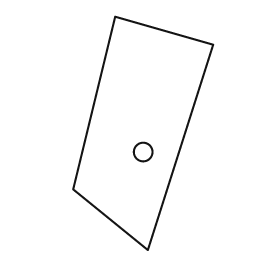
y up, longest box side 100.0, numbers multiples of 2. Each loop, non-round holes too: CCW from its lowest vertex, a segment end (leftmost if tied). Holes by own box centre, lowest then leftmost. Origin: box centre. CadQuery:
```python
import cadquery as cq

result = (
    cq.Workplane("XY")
    .moveTo(2.0, -50.0)
    .lineTo(30.0, 38.0)
    .lineTo(-12.0, 50.0)
    .lineTo(-30.0, -24.0)
    .close()
    .moveTo(0.0, -8.0)
    .circle(4.0)
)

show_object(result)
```